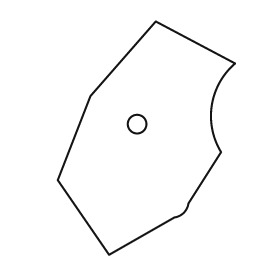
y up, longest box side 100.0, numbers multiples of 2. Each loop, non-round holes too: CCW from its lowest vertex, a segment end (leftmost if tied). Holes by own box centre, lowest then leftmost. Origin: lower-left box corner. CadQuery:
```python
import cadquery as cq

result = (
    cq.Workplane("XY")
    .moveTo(22.0, 0.0)
    .lineTo(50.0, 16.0)
    .threePointArc((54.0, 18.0), (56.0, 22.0))
    .lineTo(70.0, 44.0)
    .threePointArc((66.0, 64.0), (76.0, 82.0))
    .lineTo(42.0, 100.0)
    .lineTo(14.0, 68.0)
    .lineTo(0.0, 32.0)
    .close()
    .moveTo(34.0, 56.0)
    .circle(4.0)
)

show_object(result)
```